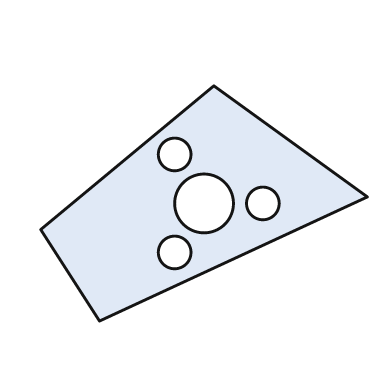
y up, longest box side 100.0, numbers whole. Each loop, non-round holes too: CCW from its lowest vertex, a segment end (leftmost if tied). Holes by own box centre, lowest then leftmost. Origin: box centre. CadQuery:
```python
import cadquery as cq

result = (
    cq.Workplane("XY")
    .moveTo(-32.0, -36.0)
    .lineTo(50.0, 2.0)
    .lineTo(3.0, 36.0)
    .lineTo(-50.0, -8.0)
    .close()
    .moveTo(-9.0, -15.0)
    .circle(5.0)
    .moveTo(0.0, 0.0)
    .circle(9.0)
    .moveTo(18.0, 0.0)
    .circle(5.0)
    .moveTo(-9.0, 15.0)
    .circle(5.0)
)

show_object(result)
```